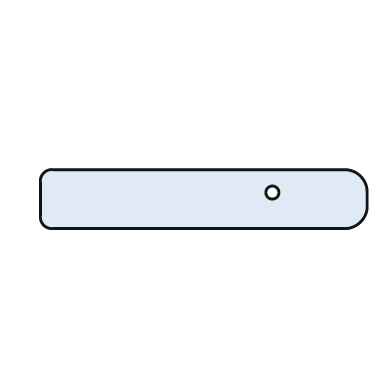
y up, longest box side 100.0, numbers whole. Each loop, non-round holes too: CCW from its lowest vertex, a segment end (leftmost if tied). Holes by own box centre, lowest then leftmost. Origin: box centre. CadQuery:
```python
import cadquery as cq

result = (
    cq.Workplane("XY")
    .moveTo(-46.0, -9.0)
    .lineTo(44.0, -9.0)
    .threePointArc((48.0, -7.0), (50.0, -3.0))
    .lineTo(50.0, 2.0)
    .threePointArc((48.0, 7.0), (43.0, 9.0))
    .lineTo(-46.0, 9.0)
    .threePointArc((-49.0, 8.0), (-50.0, 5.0))
    .lineTo(-50.0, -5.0)
    .threePointArc((-49.0, -8.0), (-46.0, -9.0))
    .close()
    .moveTo(21.0, 2.0)
    .circle(2.0)
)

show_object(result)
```